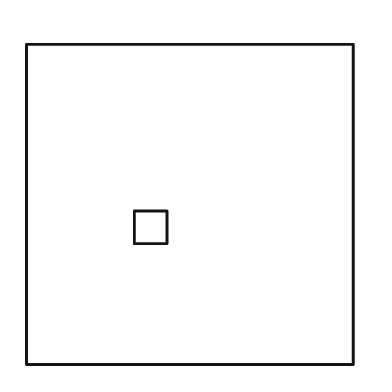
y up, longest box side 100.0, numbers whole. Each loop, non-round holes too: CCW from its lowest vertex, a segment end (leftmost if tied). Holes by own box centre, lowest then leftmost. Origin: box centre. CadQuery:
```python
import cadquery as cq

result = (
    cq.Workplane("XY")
    .moveTo(-50.0, -49.0)
    .lineTo(50.0, -49.0)
    .lineTo(50.0, 49.0)
    .lineTo(-50.0, 49.0)
    .close()
    .moveTo(-17.0, -12.0)
    .lineTo(-7.0, -12.0)
    .lineTo(-7.0, -2.0)
    .lineTo(-17.0, -2.0)
    .close()
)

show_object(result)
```